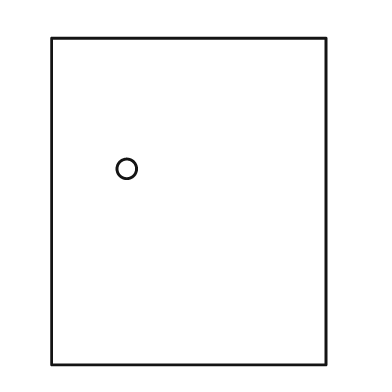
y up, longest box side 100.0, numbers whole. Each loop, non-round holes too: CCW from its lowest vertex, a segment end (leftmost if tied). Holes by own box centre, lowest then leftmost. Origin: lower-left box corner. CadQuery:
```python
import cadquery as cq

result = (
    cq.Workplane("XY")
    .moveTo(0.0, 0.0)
    .lineTo(84.0, 0.0)
    .lineTo(84.0, 100.0)
    .lineTo(0.0, 100.0)
    .close()
    .moveTo(23.0, 60.0)
    .circle(3.0)
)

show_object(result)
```